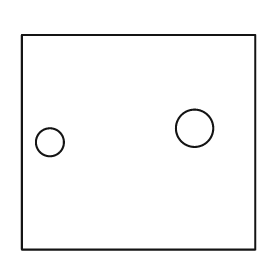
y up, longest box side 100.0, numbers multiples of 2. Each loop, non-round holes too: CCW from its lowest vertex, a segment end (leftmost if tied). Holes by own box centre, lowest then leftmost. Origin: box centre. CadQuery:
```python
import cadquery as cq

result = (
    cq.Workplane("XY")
    .moveTo(-50.0, -46.0)
    .lineTo(50.0, -46.0)
    .lineTo(50.0, 46.0)
    .lineTo(-50.0, 46.0)
    .close()
    .moveTo(-38.0, 0.0)
    .circle(6.0)
    .moveTo(24.0, 6.0)
    .circle(8.0)
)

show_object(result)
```